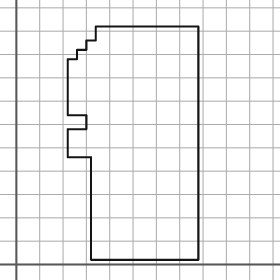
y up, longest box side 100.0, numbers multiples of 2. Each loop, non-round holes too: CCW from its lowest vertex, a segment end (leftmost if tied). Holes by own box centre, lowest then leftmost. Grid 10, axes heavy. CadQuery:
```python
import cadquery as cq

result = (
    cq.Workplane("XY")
    .moveTo(32.0, 2.0)
    .lineTo(78.0, 2.0)
    .lineTo(78.0, 102.0)
    .lineTo(34.0, 102.0)
    .lineTo(34.0, 96.0)
    .lineTo(30.0, 96.0)
    .lineTo(30.0, 92.0)
    .lineTo(26.0, 92.0)
    .lineTo(26.0, 88.0)
    .lineTo(22.0, 88.0)
    .lineTo(22.0, 64.0)
    .lineTo(30.0, 64.0)
    .lineTo(30.0, 58.0)
    .lineTo(22.0, 58.0)
    .lineTo(22.0, 46.0)
    .lineTo(32.0, 46.0)
    .close()
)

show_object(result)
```